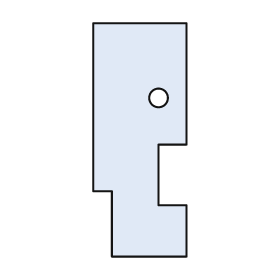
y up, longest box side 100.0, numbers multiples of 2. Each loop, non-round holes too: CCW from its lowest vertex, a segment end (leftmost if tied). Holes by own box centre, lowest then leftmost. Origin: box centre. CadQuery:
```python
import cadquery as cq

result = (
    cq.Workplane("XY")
    .moveTo(-12.0, -50.0)
    .lineTo(20.0, -50.0)
    .lineTo(20.0, -28.0)
    .lineTo(8.0, -28.0)
    .lineTo(8.0, -2.0)
    .lineTo(20.0, -2.0)
    .lineTo(20.0, 50.0)
    .lineTo(-20.0, 50.0)
    .lineTo(-20.0, -22.0)
    .lineTo(-12.0, -22.0)
    .close()
    .moveTo(8.0, 18.0)
    .circle(4.0)
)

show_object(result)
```